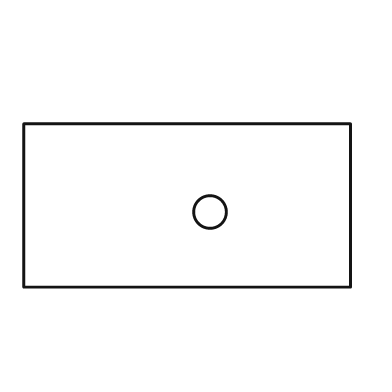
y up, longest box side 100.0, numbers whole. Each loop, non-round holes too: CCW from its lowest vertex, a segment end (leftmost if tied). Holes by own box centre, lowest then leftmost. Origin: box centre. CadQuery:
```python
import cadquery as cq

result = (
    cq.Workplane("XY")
    .moveTo(-50.0, -25.0)
    .lineTo(50.0, -25.0)
    .lineTo(50.0, 25.0)
    .lineTo(-50.0, 25.0)
    .close()
    .moveTo(7.0, -2.0)
    .circle(5.0)
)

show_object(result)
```